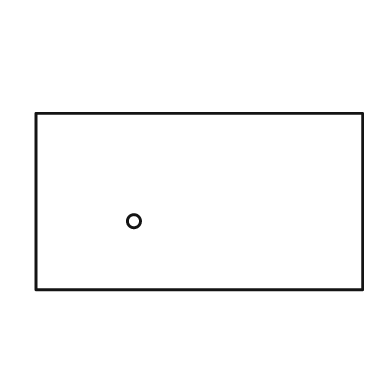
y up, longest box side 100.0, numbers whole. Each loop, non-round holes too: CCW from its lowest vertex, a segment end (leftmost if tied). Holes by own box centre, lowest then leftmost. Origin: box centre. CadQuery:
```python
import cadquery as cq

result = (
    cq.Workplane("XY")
    .moveTo(-50.0, -27.0)
    .lineTo(50.0, -27.0)
    .lineTo(50.0, 27.0)
    .lineTo(-50.0, 27.0)
    .close()
    .moveTo(-20.0, -6.0)
    .circle(2.0)
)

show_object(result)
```